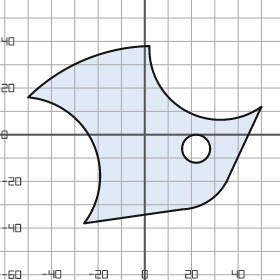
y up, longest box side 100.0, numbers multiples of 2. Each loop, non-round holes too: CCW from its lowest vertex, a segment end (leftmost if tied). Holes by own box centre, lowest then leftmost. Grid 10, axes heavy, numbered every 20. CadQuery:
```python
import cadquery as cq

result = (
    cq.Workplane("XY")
    .moveTo(-26.0, -38.0)
    .lineTo(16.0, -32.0)
    .threePointArc((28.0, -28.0), (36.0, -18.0))
    .lineTo(50.0, 12.0)
    .threePointArc((18.0, 10.0), (2.0, 38.0))
    .threePointArc((-26.0, 32.0), (-50.0, 16.0))
    .threePointArc((-22.0, -4.0), (-26.0, -38.0))
    .close()
    .moveTo(22.0, -6.0)
    .circle(6.0)
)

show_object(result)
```